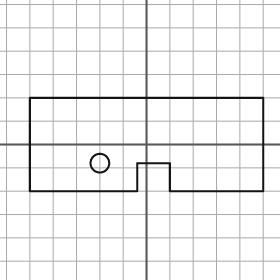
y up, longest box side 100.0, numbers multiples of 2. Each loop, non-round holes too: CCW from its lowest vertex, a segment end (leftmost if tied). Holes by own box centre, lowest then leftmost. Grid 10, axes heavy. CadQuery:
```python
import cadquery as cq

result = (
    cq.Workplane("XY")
    .moveTo(-50.0, -20.0)
    .lineTo(-4.0, -20.0)
    .lineTo(-4.0, -8.0)
    .lineTo(10.0, -8.0)
    .lineTo(10.0, -20.0)
    .lineTo(50.0, -20.0)
    .lineTo(50.0, 20.0)
    .lineTo(-50.0, 20.0)
    .close()
    .moveTo(-20.0, -8.0)
    .circle(4.0)
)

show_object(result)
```